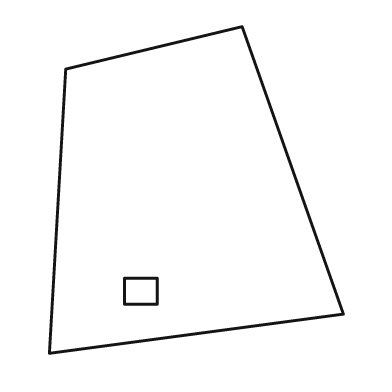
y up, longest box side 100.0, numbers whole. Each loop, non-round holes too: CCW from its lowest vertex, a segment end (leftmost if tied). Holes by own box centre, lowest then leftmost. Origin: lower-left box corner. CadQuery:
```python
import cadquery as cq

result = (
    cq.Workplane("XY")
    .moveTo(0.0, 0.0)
    .lineTo(90.0, 12.0)
    .lineTo(59.0, 100.0)
    .lineTo(5.0, 87.0)
    .close()
    .moveTo(23.0, 15.0)
    .lineTo(33.0, 15.0)
    .lineTo(33.0, 23.0)
    .lineTo(23.0, 23.0)
    .close()
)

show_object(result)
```